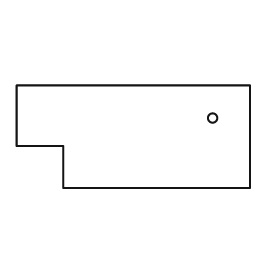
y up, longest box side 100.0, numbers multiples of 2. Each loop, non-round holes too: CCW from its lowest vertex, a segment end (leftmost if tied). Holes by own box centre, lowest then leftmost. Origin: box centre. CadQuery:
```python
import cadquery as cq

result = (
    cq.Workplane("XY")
    .moveTo(-30.0, -22.0)
    .lineTo(50.0, -22.0)
    .lineTo(50.0, 22.0)
    .lineTo(-50.0, 22.0)
    .lineTo(-50.0, -4.0)
    .lineTo(-30.0, -4.0)
    .close()
    .moveTo(34.0, 8.0)
    .circle(2.0)
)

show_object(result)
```